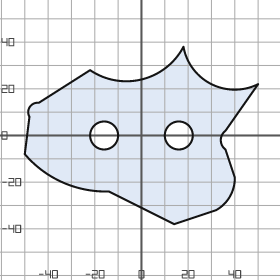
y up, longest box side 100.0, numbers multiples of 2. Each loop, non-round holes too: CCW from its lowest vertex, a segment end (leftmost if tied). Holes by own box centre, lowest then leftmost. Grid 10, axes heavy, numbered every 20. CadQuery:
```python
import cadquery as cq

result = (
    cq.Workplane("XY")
    .moveTo(14.0, -38.0)
    .lineTo(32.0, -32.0)
    .threePointArc((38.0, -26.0), (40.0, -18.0))
    .lineTo(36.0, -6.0)
    .threePointArc((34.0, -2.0), (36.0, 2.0))
    .lineTo(50.0, 22.0)
    .threePointArc((30.0, 22.0), (18.0, 38.0))
    .threePointArc((0.0, 24.0), (-22.0, 28.0))
    .lineTo(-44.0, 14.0)
    .threePointArc((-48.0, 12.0), (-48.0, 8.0))
    .lineTo(-50.0, -8.0)
    .threePointArc((-34.0, -20.0), (-14.0, -24.0))
    .close()
    .moveTo(-16.0, 0.0)
    .circle(6.0)
    .moveTo(16.0, 0.0)
    .circle(6.0)
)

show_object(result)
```